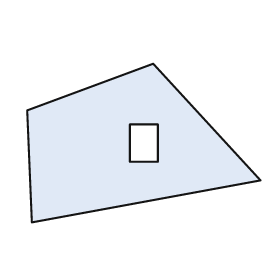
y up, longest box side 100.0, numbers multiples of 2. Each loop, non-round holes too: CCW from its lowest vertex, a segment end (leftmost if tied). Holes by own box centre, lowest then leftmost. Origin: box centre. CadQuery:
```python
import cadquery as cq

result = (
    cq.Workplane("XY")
    .moveTo(-48.0, -34.0)
    .lineTo(50.0, -16.0)
    .lineTo(4.0, 34.0)
    .lineTo(-50.0, 14.0)
    .close()
    .moveTo(-6.0, -8.0)
    .lineTo(6.0, -8.0)
    .lineTo(6.0, 8.0)
    .lineTo(-6.0, 8.0)
    .close()
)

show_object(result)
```